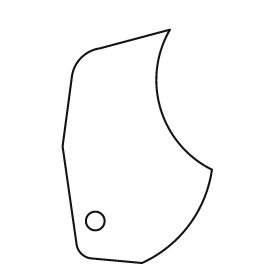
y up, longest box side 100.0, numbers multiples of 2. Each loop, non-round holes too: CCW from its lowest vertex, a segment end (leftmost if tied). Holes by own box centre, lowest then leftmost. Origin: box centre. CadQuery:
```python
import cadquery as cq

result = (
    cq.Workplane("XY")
    .moveTo(2.0, -50.0)
    .threePointArc((22.0, -34.0), (32.0, -10.0))
    .threePointArc((10.0, 16.0), (14.0, 50.0))
    .lineTo(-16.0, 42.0)
    .threePointArc((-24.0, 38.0), (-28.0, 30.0))
    .lineTo(-32.0, 0.0)
    .lineTo(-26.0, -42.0)
    .threePointArc((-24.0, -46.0), (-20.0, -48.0))
    .close()
    .moveTo(-18.0, -32.0)
    .circle(4.0)
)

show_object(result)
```